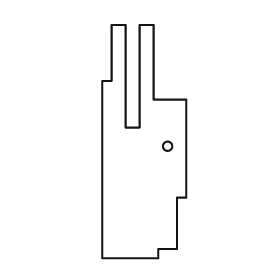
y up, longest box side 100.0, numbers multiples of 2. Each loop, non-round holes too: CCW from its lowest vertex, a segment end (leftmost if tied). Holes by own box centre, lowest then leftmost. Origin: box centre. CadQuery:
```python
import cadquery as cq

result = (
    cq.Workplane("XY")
    .moveTo(-18.0, -50.0)
    .lineTo(6.0, -50.0)
    .lineTo(6.0, -46.0)
    .lineTo(14.0, -46.0)
    .lineTo(14.0, -24.0)
    .lineTo(18.0, -24.0)
    .lineTo(18.0, 18.0)
    .lineTo(4.0, 18.0)
    .lineTo(4.0, 50.0)
    .lineTo(-2.0, 50.0)
    .lineTo(-2.0, 6.0)
    .lineTo(-8.0, 6.0)
    .lineTo(-8.0, 50.0)
    .lineTo(-14.0, 50.0)
    .lineTo(-14.0, 26.0)
    .lineTo(-18.0, 26.0)
    .close()
    .moveTo(10.0, -2.0)
    .circle(2.0)
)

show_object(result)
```